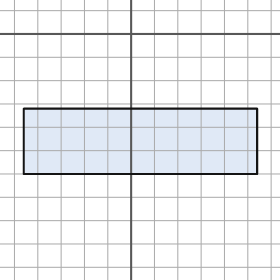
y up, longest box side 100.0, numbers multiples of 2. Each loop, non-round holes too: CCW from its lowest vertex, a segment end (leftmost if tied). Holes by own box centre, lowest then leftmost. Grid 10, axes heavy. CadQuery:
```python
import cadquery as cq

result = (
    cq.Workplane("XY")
    .moveTo(-46.0, -60.0)
    .lineTo(54.0, -60.0)
    .lineTo(54.0, -32.0)
    .lineTo(-46.0, -32.0)
    .close()
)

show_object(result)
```